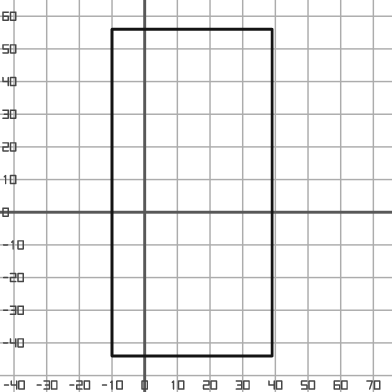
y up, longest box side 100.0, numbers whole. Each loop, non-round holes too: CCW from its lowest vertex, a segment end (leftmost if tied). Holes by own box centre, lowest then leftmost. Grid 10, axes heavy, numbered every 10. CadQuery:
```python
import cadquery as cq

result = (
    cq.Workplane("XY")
    .moveTo(-10.0, -44.0)
    .lineTo(39.0, -44.0)
    .lineTo(39.0, 56.0)
    .lineTo(-10.0, 56.0)
    .close()
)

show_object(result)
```